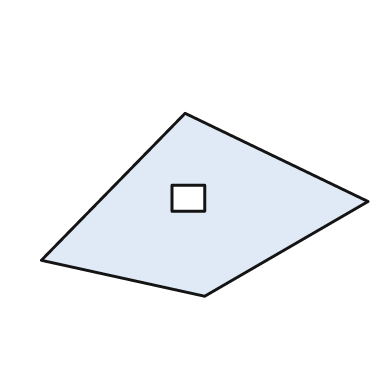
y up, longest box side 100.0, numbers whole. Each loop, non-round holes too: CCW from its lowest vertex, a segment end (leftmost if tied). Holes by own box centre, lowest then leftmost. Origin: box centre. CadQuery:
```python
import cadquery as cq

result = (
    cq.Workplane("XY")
    .moveTo(0.0, -28.0)
    .lineTo(50.0, 1.0)
    .lineTo(-6.0, 28.0)
    .lineTo(-50.0, -17.0)
    .close()
    .moveTo(-10.0, -2.0)
    .lineTo(0.0, -2.0)
    .lineTo(0.0, 6.0)
    .lineTo(-10.0, 6.0)
    .close()
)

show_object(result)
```